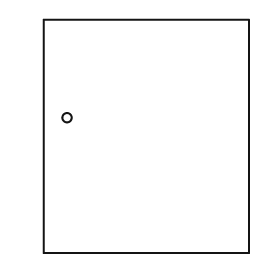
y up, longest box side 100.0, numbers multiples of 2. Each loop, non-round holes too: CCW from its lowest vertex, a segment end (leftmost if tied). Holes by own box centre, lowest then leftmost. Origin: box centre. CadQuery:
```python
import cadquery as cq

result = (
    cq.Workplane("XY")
    .moveTo(-44.0, -50.0)
    .lineTo(44.0, -50.0)
    .lineTo(44.0, 50.0)
    .lineTo(-44.0, 50.0)
    .close()
    .moveTo(-34.0, 8.0)
    .circle(2.0)
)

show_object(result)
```